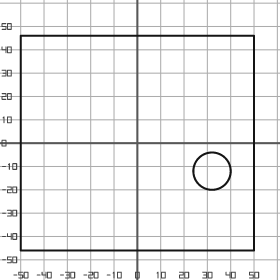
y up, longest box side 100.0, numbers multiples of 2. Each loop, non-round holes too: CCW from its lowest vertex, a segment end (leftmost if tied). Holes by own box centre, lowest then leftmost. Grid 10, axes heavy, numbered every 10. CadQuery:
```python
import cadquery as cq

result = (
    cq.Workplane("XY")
    .moveTo(-50.0, -46.0)
    .lineTo(50.0, -46.0)
    .lineTo(50.0, 46.0)
    .lineTo(-50.0, 46.0)
    .close()
    .moveTo(32.0, -12.0)
    .circle(8.0)
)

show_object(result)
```